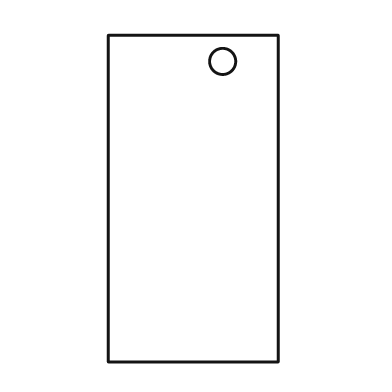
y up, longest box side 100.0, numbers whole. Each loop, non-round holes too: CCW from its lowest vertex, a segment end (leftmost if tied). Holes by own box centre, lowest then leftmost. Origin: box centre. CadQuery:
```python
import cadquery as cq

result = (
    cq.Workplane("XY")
    .moveTo(-26.0, -50.0)
    .lineTo(26.0, -50.0)
    .lineTo(26.0, 50.0)
    .lineTo(-26.0, 50.0)
    .close()
    .moveTo(9.0, 42.0)
    .circle(4.0)
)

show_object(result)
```